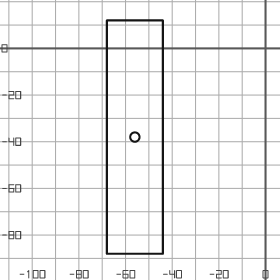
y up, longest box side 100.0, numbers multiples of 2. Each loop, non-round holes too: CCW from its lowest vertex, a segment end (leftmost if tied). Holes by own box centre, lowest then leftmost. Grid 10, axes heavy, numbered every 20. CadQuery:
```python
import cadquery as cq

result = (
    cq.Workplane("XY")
    .moveTo(-68.0, -88.0)
    .lineTo(-44.0, -88.0)
    .lineTo(-44.0, 12.0)
    .lineTo(-68.0, 12.0)
    .close()
    .moveTo(-56.0, -38.0)
    .circle(2.0)
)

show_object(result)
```